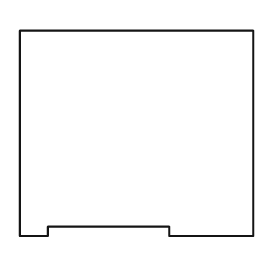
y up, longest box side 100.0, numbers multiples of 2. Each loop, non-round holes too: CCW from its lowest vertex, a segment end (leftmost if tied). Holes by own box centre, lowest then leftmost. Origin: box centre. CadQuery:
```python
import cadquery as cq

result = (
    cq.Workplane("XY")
    .moveTo(-50.0, -44.0)
    .lineTo(-38.0, -44.0)
    .lineTo(-38.0, -40.0)
    .lineTo(14.0, -40.0)
    .lineTo(14.0, -44.0)
    .lineTo(50.0, -44.0)
    .lineTo(50.0, 44.0)
    .lineTo(-50.0, 44.0)
    .close()
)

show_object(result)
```